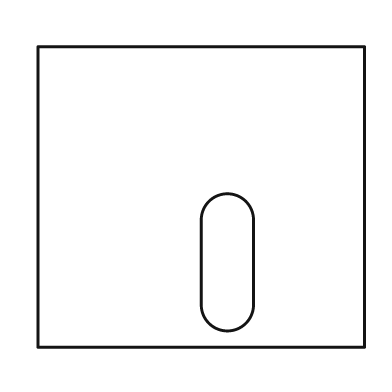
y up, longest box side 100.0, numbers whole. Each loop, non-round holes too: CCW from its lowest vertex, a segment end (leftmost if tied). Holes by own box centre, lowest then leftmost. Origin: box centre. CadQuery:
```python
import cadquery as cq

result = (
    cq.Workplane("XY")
    .moveTo(-50.0, -46.0)
    .lineTo(50.0, -46.0)
    .lineTo(50.0, 46.0)
    .lineTo(-50.0, 46.0)
    .close()
    .moveTo(0.0, -33.0)
    .threePointArc((8.0, -41.0), (16.0, -33.0))
    .lineTo(16.0, -7.0)
    .threePointArc((8.0, 1.0), (0.0, -7.0))
    .close()
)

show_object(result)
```